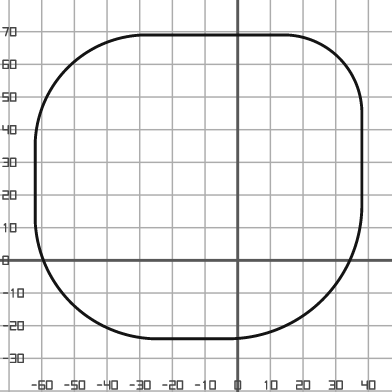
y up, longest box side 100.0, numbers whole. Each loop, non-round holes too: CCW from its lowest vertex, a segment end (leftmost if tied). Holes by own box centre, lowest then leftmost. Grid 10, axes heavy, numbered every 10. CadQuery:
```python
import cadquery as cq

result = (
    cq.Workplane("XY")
    .moveTo(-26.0, -24.0)
    .lineTo(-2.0, -24.0)
    .threePointArc((26.0, -12.0), (38.0, 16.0))
    .lineTo(38.0, 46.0)
    .threePointArc((31.0, 62.0), (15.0, 69.0))
    .lineTo(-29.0, 69.0)
    .threePointArc((-52.0, 59.0), (-62.0, 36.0))
    .lineTo(-62.0, 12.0)
    .threePointArc((-51.0, -13.0), (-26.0, -24.0))
    .close()
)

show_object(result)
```